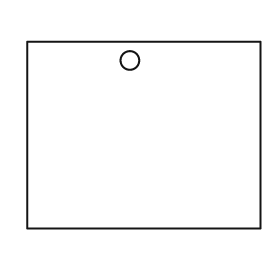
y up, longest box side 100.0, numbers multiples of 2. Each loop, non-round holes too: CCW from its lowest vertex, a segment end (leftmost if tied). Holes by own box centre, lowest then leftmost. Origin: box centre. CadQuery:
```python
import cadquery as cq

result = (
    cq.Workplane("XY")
    .moveTo(-50.0, -40.0)
    .lineTo(50.0, -40.0)
    .lineTo(50.0, 40.0)
    .lineTo(-50.0, 40.0)
    .close()
    .moveTo(-6.0, 32.0)
    .circle(4.0)
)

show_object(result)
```